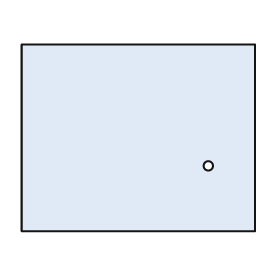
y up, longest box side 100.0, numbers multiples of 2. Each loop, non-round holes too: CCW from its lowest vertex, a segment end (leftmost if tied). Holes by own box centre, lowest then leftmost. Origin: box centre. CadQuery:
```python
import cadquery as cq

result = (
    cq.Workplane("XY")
    .moveTo(-50.0, -40.0)
    .lineTo(50.0, -40.0)
    .lineTo(50.0, 40.0)
    .lineTo(-50.0, 40.0)
    .close()
    .moveTo(30.0, -12.0)
    .circle(2.0)
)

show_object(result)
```